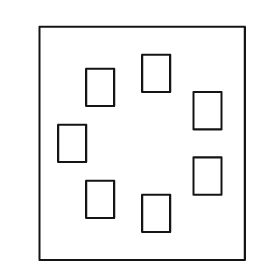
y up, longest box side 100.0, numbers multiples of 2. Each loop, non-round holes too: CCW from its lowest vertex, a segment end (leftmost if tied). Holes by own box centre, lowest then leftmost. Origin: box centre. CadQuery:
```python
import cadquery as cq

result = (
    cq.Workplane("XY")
    .moveTo(-44.0, -50.0)
    .lineTo(44.0, -50.0)
    .lineTo(44.0, 50.0)
    .lineTo(-44.0, 50.0)
    .close()
    .moveTo(0.0, -38.0)
    .lineTo(12.0, -38.0)
    .lineTo(12.0, -22.0)
    .lineTo(0.0, -22.0)
    .close()
    .moveTo(-24.0, -32.0)
    .lineTo(-12.0, -32.0)
    .lineTo(-12.0, -16.0)
    .lineTo(-24.0, -16.0)
    .close()
    .moveTo(22.0, -22.0)
    .lineTo(34.0, -22.0)
    .lineTo(34.0, -6.0)
    .lineTo(22.0, -6.0)
    .close()
    .moveTo(-36.0, -8.0)
    .lineTo(-24.0, -8.0)
    .lineTo(-24.0, 8.0)
    .lineTo(-36.0, 8.0)
    .close()
    .moveTo(22.0, 6.0)
    .lineTo(34.0, 6.0)
    .lineTo(34.0, 22.0)
    .lineTo(22.0, 22.0)
    .close()
    .moveTo(-24.0, 16.0)
    .lineTo(-12.0, 16.0)
    .lineTo(-12.0, 32.0)
    .lineTo(-24.0, 32.0)
    .close()
    .moveTo(0.0, 22.0)
    .lineTo(12.0, 22.0)
    .lineTo(12.0, 38.0)
    .lineTo(0.0, 38.0)
    .close()
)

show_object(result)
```